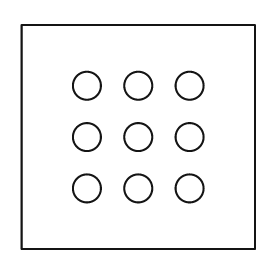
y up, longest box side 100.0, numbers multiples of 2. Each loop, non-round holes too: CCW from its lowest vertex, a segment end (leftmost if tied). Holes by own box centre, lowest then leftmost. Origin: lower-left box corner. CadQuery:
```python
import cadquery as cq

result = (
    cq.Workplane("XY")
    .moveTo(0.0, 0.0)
    .lineTo(100.0, 0.0)
    .lineTo(100.0, 96.0)
    .lineTo(0.0, 96.0)
    .close()
    .moveTo(28.0, 26.0)
    .circle(6.0)
    .moveTo(50.0, 26.0)
    .circle(6.0)
    .moveTo(72.0, 26.0)
    .circle(6.0)
    .moveTo(28.0, 48.0)
    .circle(6.0)
    .moveTo(50.0, 48.0)
    .circle(6.0)
    .moveTo(72.0, 48.0)
    .circle(6.0)
    .moveTo(28.0, 70.0)
    .circle(6.0)
    .moveTo(50.0, 70.0)
    .circle(6.0)
    .moveTo(72.0, 70.0)
    .circle(6.0)
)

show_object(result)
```